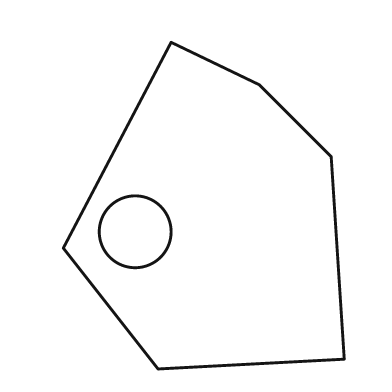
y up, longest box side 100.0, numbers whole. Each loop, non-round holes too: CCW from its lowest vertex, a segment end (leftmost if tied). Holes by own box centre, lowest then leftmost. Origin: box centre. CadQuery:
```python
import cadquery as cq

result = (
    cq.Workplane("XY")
    .moveTo(-14.0, -50.0)
    .lineTo(43.0, -47.0)
    .lineTo(39.0, 15.0)
    .lineTo(17.0, 37.0)
    .lineTo(-10.0, 50.0)
    .lineTo(-43.0, -13.0)
    .close()
    .moveTo(-21.0, -8.0)
    .circle(11.0)
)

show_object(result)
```